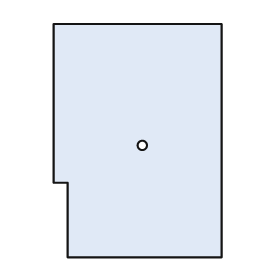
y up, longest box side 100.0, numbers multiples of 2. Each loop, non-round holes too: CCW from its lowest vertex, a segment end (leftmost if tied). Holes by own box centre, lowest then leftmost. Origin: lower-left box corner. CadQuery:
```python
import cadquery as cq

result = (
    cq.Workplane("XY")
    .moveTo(6.0, 0.0)
    .lineTo(72.0, 0.0)
    .lineTo(72.0, 100.0)
    .lineTo(0.0, 100.0)
    .lineTo(0.0, 32.0)
    .lineTo(6.0, 32.0)
    .close()
    .moveTo(38.0, 48.0)
    .circle(2.0)
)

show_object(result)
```